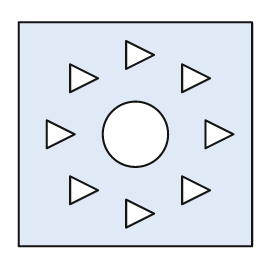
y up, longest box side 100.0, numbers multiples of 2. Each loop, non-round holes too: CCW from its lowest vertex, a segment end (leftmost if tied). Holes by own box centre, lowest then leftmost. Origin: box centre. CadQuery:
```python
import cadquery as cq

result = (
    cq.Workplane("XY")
    .moveTo(-50.0, -48.0)
    .lineTo(50.0, -48.0)
    .lineTo(50.0, 48.0)
    .lineTo(-50.0, 48.0)
    .close()
    .moveTo(-4.0, -40.0)
    .lineTo(8.0, -34.0)
    .lineTo(-4.0, -28.0)
    .close()
    .moveTo(-28.0, -30.0)
    .lineTo(-16.0, -24.0)
    .lineTo(-28.0, -18.0)
    .close()
    .moveTo(20.0, -30.0)
    .lineTo(32.0, -24.0)
    .lineTo(20.0, -18.0)
    .close()
    .moveTo(-38.0, -6.0)
    .lineTo(-26.0, 0.0)
    .lineTo(-38.0, 6.0)
    .close()
    .moveTo(0.0, 0.0)
    .circle(14.0)
    .moveTo(30.0, -6.0)
    .lineTo(42.0, 0.0)
    .lineTo(30.0, 6.0)
    .close()
    .moveTo(-28.0, 18.0)
    .lineTo(-16.0, 24.0)
    .lineTo(-28.0, 30.0)
    .close()
    .moveTo(20.0, 18.0)
    .lineTo(32.0, 24.0)
    .lineTo(20.0, 30.0)
    .close()
    .moveTo(-4.0, 28.0)
    .lineTo(8.0, 34.0)
    .lineTo(-4.0, 40.0)
    .close()
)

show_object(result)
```